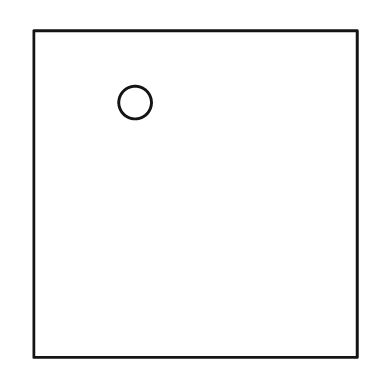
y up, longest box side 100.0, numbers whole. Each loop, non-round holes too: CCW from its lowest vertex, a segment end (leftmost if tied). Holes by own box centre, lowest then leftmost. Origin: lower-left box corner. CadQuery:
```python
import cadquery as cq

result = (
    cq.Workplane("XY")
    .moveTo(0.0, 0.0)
    .lineTo(99.0, 0.0)
    .lineTo(99.0, 100.0)
    .lineTo(0.0, 100.0)
    .close()
    .moveTo(31.0, 78.0)
    .circle(5.0)
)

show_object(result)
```